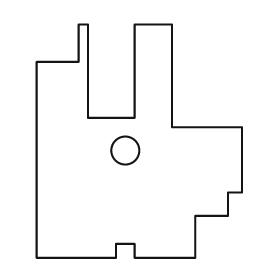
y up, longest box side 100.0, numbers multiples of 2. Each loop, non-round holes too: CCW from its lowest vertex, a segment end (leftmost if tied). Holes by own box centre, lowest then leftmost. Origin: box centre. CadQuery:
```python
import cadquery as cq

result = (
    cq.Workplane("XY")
    .moveTo(-44.0, -50.0)
    .lineTo(-10.0, -50.0)
    .lineTo(-10.0, -44.0)
    .lineTo(-2.0, -44.0)
    .lineTo(-2.0, -50.0)
    .lineTo(24.0, -50.0)
    .lineTo(24.0, -32.0)
    .lineTo(38.0, -32.0)
    .lineTo(38.0, -22.0)
    .lineTo(44.0, -22.0)
    .lineTo(44.0, 6.0)
    .lineTo(14.0, 6.0)
    .lineTo(14.0, 50.0)
    .lineTo(-2.0, 50.0)
    .lineTo(-2.0, 10.0)
    .lineTo(-22.0, 10.0)
    .lineTo(-22.0, 50.0)
    .lineTo(-26.0, 50.0)
    .lineTo(-26.0, 34.0)
    .lineTo(-44.0, 34.0)
    .close()
    .moveTo(-6.0, -4.0)
    .circle(6.0)
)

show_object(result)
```